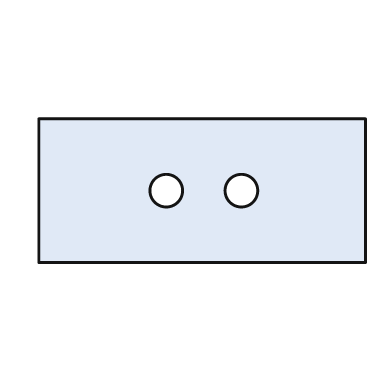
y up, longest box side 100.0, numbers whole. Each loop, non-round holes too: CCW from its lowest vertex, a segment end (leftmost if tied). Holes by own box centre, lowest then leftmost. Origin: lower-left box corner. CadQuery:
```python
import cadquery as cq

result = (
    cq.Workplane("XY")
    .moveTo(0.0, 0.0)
    .lineTo(100.0, 0.0)
    .lineTo(100.0, 44.0)
    .lineTo(0.0, 44.0)
    .close()
    .moveTo(39.0, 22.0)
    .circle(5.0)
    .moveTo(62.0, 22.0)
    .circle(5.0)
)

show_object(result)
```